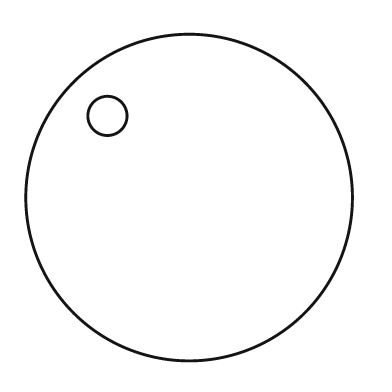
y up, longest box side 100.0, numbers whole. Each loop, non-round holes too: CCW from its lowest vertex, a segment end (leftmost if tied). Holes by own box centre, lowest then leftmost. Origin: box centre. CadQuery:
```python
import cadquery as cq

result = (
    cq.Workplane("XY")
    .moveTo(0.0, 0.0)
    .circle(50.0)
    .moveTo(-25.0, 25.0)
    .circle(6.0)
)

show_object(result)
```